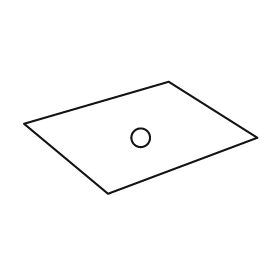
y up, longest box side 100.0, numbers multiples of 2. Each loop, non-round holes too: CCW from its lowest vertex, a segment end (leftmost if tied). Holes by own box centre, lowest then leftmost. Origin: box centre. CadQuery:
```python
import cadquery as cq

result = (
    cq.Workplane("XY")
    .moveTo(-14.0, -24.0)
    .lineTo(50.0, 0.0)
    .lineTo(12.0, 24.0)
    .lineTo(-50.0, 6.0)
    .close()
    .moveTo(0.0, 0.0)
    .circle(4.0)
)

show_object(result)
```